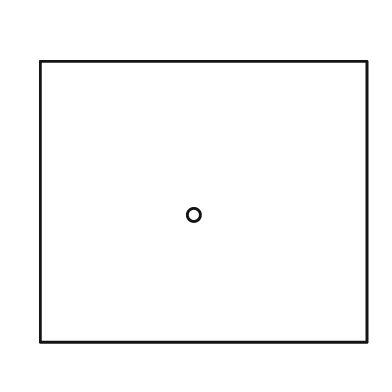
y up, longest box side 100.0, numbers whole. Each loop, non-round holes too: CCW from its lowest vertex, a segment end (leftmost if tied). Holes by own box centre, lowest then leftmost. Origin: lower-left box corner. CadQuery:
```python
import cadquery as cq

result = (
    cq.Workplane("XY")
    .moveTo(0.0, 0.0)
    .lineTo(100.0, 0.0)
    .lineTo(100.0, 86.0)
    .lineTo(0.0, 86.0)
    .close()
    .moveTo(47.0, 39.0)
    .circle(2.0)
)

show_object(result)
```